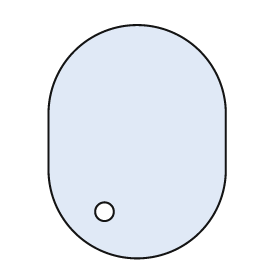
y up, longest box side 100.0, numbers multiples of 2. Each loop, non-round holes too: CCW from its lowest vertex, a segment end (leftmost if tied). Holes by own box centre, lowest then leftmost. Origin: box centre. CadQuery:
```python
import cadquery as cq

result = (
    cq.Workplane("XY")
    .moveTo(-38.0, -12.0)
    .threePointArc((0.0, -50.0), (38.0, -12.0))
    .lineTo(38.0, 12.0)
    .threePointArc((0.0, 50.0), (-38.0, 12.0))
    .close()
    .moveTo(-14.0, -30.0)
    .circle(4.0)
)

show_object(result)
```